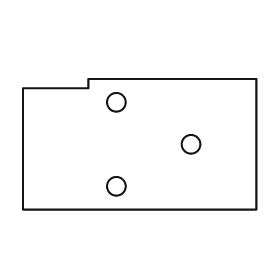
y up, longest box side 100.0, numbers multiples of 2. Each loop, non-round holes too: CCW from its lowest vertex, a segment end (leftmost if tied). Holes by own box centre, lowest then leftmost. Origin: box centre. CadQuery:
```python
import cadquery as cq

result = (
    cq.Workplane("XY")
    .moveTo(-50.0, -28.0)
    .lineTo(50.0, -28.0)
    .lineTo(50.0, 28.0)
    .lineTo(-22.0, 28.0)
    .lineTo(-22.0, 24.0)
    .lineTo(-50.0, 24.0)
    .close()
    .moveTo(-10.0, -18.0)
    .circle(4.0)
    .moveTo(22.0, 0.0)
    .circle(4.0)
    .moveTo(-10.0, 18.0)
    .circle(4.0)
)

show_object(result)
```